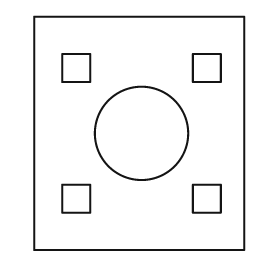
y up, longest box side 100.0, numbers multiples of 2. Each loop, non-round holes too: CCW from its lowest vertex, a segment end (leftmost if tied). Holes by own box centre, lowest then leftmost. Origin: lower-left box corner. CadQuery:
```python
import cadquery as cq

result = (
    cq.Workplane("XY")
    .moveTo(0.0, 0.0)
    .lineTo(90.0, 0.0)
    .lineTo(90.0, 100.0)
    .lineTo(0.0, 100.0)
    .close()
    .moveTo(12.0, 16.0)
    .lineTo(24.0, 16.0)
    .lineTo(24.0, 28.0)
    .lineTo(12.0, 28.0)
    .close()
    .moveTo(68.0, 16.0)
    .lineTo(80.0, 16.0)
    .lineTo(80.0, 28.0)
    .lineTo(68.0, 28.0)
    .close()
    .moveTo(46.0, 50.0)
    .circle(20.0)
    .moveTo(12.0, 72.0)
    .lineTo(24.0, 72.0)
    .lineTo(24.0, 84.0)
    .lineTo(12.0, 84.0)
    .close()
    .moveTo(68.0, 72.0)
    .lineTo(80.0, 72.0)
    .lineTo(80.0, 84.0)
    .lineTo(68.0, 84.0)
    .close()
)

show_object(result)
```